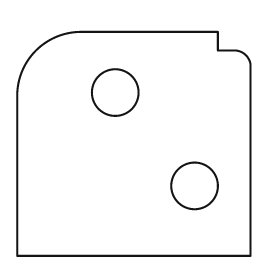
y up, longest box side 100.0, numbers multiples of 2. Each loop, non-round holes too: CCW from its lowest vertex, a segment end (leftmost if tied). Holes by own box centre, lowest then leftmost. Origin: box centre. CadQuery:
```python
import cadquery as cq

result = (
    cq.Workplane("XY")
    .moveTo(-50.0, -48.0)
    .lineTo(50.0, -48.0)
    .lineTo(50.0, 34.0)
    .threePointArc((48.0, 38.0), (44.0, 40.0))
    .lineTo(36.0, 40.0)
    .lineTo(36.0, 48.0)
    .lineTo(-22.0, 48.0)
    .threePointArc((-42.0, 40.0), (-50.0, 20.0))
    .close()
    .moveTo(26.0, -18.0)
    .circle(10.0)
    .moveTo(-8.0, 22.0)
    .circle(10.0)
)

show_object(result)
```